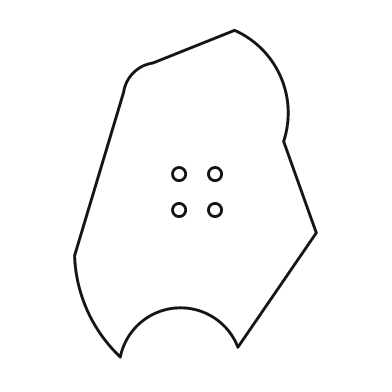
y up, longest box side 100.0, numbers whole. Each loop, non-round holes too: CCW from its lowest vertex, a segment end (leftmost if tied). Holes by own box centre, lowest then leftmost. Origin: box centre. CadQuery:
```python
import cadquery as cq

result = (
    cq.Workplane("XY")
    .moveTo(-23.0, -50.0)
    .threePointArc((-6.0, -35.0), (13.0, -47.0))
    .lineTo(37.0, -12.0)
    .lineTo(27.0, 16.0)
    .threePointArc((26.0, 36.0), (12.0, 50.0))
    .lineTo(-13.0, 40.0)
    .threePointArc((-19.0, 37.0), (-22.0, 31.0))
    .lineTo(-37.0, -19.0)
    .threePointArc((-33.0, -36.0), (-23.0, -50.0))
    .close()
    .moveTo(-5.0, -5.0)
    .circle(2.0)
    .moveTo(6.0, -5.0)
    .circle(2.0)
    .moveTo(-5.0, 6.0)
    .circle(2.0)
    .moveTo(6.0, 6.0)
    .circle(2.0)
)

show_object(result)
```